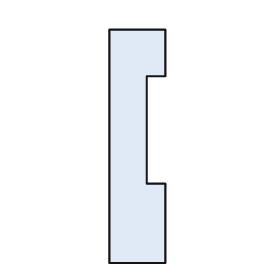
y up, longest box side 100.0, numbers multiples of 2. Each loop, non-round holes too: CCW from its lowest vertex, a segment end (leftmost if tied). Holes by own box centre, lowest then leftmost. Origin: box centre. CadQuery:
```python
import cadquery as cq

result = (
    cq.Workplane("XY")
    .moveTo(-12.0, -50.0)
    .lineTo(12.0, -50.0)
    .lineTo(12.0, -16.0)
    .lineTo(4.0, -16.0)
    .lineTo(4.0, 30.0)
    .lineTo(12.0, 30.0)
    .lineTo(12.0, 50.0)
    .lineTo(-12.0, 50.0)
    .close()
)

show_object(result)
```